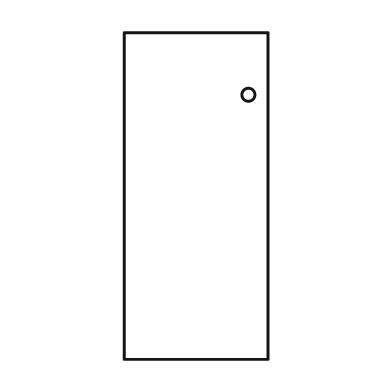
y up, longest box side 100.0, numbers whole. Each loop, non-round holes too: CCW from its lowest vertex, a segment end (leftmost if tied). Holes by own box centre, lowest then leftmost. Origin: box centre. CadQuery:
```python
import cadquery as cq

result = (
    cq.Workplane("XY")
    .moveTo(-22.0, -50.0)
    .lineTo(22.0, -50.0)
    .lineTo(22.0, 50.0)
    .lineTo(-22.0, 50.0)
    .close()
    .moveTo(16.0, 31.0)
    .circle(2.0)
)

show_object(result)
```